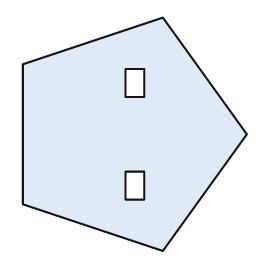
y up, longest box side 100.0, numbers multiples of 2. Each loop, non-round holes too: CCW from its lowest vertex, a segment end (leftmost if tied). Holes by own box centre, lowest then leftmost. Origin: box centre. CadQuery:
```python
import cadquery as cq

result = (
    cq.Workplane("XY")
    .moveTo(12.0, -50.0)
    .lineTo(48.0, 0.0)
    .lineTo(12.0, 50.0)
    .lineTo(-48.0, 30.0)
    .lineTo(-48.0, -30.0)
    .close()
    .moveTo(-4.0, -28.0)
    .lineTo(4.0, -28.0)
    .lineTo(4.0, -16.0)
    .lineTo(-4.0, -16.0)
    .close()
    .moveTo(-4.0, 16.0)
    .lineTo(4.0, 16.0)
    .lineTo(4.0, 28.0)
    .lineTo(-4.0, 28.0)
    .close()
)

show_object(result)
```